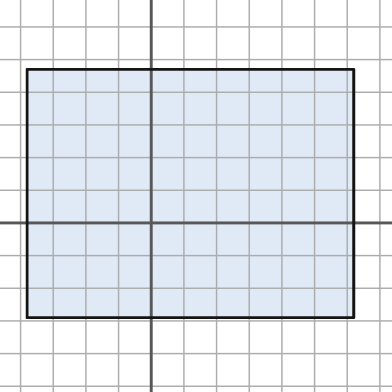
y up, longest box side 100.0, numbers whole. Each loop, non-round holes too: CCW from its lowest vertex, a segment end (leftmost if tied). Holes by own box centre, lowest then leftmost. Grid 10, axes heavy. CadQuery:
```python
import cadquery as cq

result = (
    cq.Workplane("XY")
    .moveTo(-38.0, -29.0)
    .lineTo(62.0, -29.0)
    .lineTo(62.0, 47.0)
    .lineTo(-38.0, 47.0)
    .close()
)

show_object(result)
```